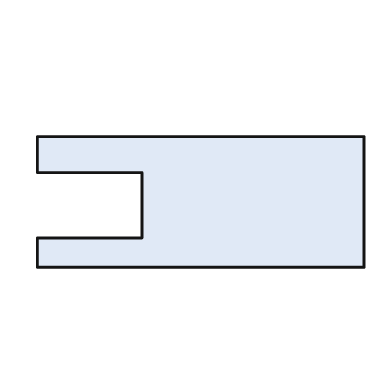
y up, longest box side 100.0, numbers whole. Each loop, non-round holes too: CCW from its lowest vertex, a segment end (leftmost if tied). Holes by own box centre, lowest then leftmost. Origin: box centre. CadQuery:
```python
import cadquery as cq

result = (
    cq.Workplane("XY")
    .moveTo(-50.0, -20.0)
    .lineTo(50.0, -20.0)
    .lineTo(50.0, 20.0)
    .lineTo(-50.0, 20.0)
    .lineTo(-50.0, 9.0)
    .lineTo(-18.0, 9.0)
    .lineTo(-18.0, -11.0)
    .lineTo(-50.0, -11.0)
    .close()
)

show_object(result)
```